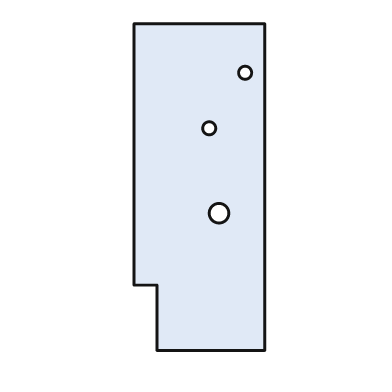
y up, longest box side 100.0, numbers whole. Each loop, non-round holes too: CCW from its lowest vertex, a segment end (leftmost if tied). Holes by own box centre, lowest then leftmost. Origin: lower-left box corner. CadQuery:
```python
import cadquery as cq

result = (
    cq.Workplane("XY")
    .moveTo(7.0, 0.0)
    .lineTo(40.0, 0.0)
    .lineTo(40.0, 100.0)
    .lineTo(0.0, 100.0)
    .lineTo(0.0, 20.0)
    .lineTo(7.0, 20.0)
    .close()
    .moveTo(26.0, 42.0)
    .circle(3.0)
    .moveTo(23.0, 68.0)
    .circle(2.0)
    .moveTo(34.0, 85.0)
    .circle(2.0)
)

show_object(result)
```